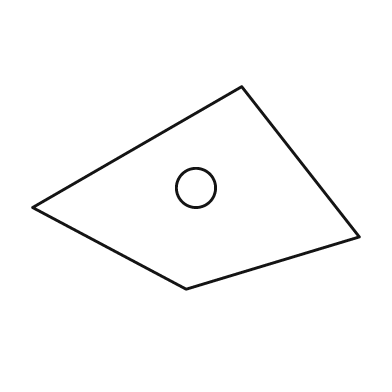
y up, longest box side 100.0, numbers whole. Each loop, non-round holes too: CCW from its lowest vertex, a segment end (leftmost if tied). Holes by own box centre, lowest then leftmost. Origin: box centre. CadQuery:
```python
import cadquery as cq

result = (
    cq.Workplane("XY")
    .moveTo(-3.0, -31.0)
    .lineTo(50.0, -15.0)
    .lineTo(14.0, 31.0)
    .lineTo(-50.0, -6.0)
    .close()
    .moveTo(0.0, 0.0)
    .circle(6.0)
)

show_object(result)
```